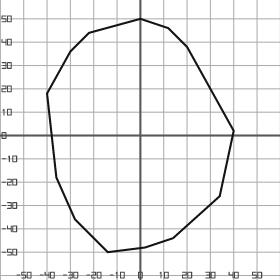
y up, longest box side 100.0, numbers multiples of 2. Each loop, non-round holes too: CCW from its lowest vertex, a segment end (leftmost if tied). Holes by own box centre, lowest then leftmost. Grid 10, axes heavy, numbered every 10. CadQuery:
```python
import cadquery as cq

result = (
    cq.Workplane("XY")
    .moveTo(-14.0, -50.0)
    .lineTo(2.0, -48.0)
    .lineTo(14.0, -44.0)
    .lineTo(34.0, -26.0)
    .lineTo(40.0, 2.0)
    .lineTo(20.0, 38.0)
    .lineTo(12.0, 46.0)
    .lineTo(0.0, 50.0)
    .lineTo(-22.0, 44.0)
    .lineTo(-30.0, 36.0)
    .lineTo(-40.0, 18.0)
    .lineTo(-36.0, -18.0)
    .lineTo(-28.0, -36.0)
    .close()
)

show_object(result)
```